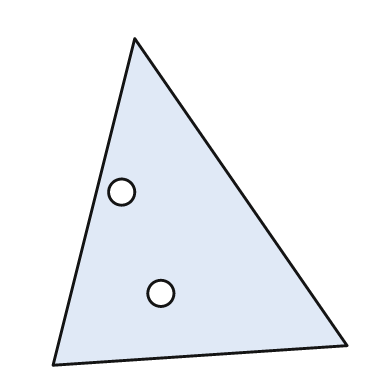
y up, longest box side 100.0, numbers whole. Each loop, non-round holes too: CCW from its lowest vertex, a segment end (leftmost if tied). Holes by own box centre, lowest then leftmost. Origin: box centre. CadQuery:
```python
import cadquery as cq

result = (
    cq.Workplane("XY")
    .moveTo(-45.0, -50.0)
    .lineTo(45.0, -44.0)
    .lineTo(-20.0, 50.0)
    .close()
    .moveTo(-12.0, -28.0)
    .circle(4.0)
    .moveTo(-24.0, 3.0)
    .circle(4.0)
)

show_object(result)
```